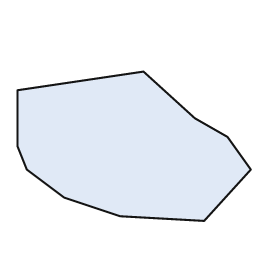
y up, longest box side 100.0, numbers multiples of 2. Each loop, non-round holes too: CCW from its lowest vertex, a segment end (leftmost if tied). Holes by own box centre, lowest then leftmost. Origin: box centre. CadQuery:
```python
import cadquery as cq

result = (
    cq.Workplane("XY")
    .moveTo(30.0, -32.0)
    .lineTo(50.0, -10.0)
    .lineTo(40.0, 4.0)
    .lineTo(26.0, 12.0)
    .lineTo(4.0, 32.0)
    .lineTo(-50.0, 24.0)
    .lineTo(-50.0, 0.0)
    .lineTo(-46.0, -10.0)
    .lineTo(-30.0, -22.0)
    .lineTo(-6.0, -30.0)
    .close()
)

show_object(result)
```